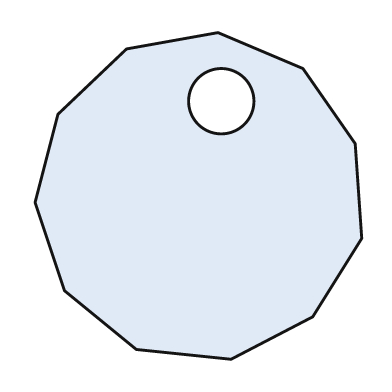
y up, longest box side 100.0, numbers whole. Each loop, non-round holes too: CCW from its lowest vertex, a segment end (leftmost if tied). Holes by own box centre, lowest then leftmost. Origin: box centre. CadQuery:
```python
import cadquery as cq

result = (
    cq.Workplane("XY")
    .moveTo(10.0, -50.0)
    .lineTo(35.0, -37.0)
    .lineTo(50.0, -13.0)
    .lineTo(48.0, 16.0)
    .lineTo(32.0, 39.0)
    .lineTo(6.0, 50.0)
    .lineTo(-22.0, 45.0)
    .lineTo(-43.0, 25.0)
    .lineTo(-50.0, -2.0)
    .lineTo(-41.0, -29.0)
    .lineTo(-19.0, -47.0)
    .close()
    .moveTo(7.0, 29.0)
    .circle(10.0)
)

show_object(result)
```